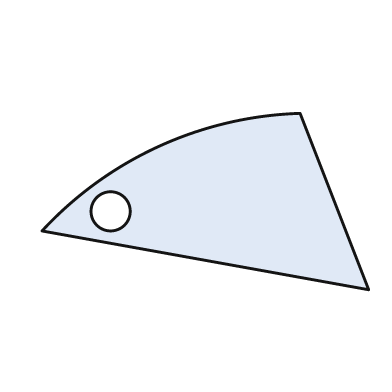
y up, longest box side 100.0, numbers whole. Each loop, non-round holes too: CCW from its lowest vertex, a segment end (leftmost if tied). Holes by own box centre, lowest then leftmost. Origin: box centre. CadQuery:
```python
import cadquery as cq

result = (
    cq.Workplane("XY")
    .moveTo(50.0, -27.0)
    .lineTo(29.0, 27.0)
    .threePointArc((-14.0, 17.0), (-50.0, -9.0))
    .close()
    .moveTo(-29.0, -3.0)
    .circle(6.0)
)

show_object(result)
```